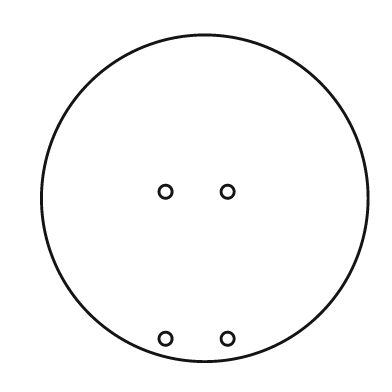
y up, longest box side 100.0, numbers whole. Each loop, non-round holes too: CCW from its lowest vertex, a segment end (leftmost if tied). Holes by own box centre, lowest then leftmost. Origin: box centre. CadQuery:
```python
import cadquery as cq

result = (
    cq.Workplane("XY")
    .moveTo(0.0, 0.0)
    .circle(50.0)
    .moveTo(-12.0, -43.0)
    .circle(2.0)
    .moveTo(7.0, -43.0)
    .circle(2.0)
    .moveTo(-12.0, 2.0)
    .circle(2.0)
    .moveTo(7.0, 2.0)
    .circle(2.0)
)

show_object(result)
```